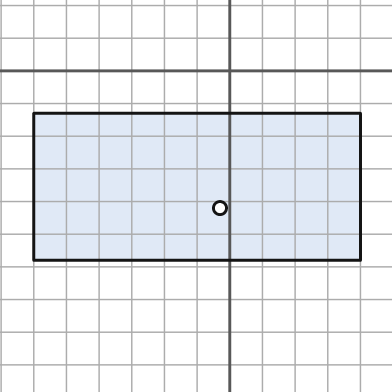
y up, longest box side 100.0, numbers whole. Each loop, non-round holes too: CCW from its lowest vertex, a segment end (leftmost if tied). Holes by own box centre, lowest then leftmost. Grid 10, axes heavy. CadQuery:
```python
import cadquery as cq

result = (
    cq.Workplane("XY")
    .moveTo(-60.0, -58.0)
    .lineTo(40.0, -58.0)
    .lineTo(40.0, -13.0)
    .lineTo(-60.0, -13.0)
    .close()
    .moveTo(-3.0, -42.0)
    .circle(2.0)
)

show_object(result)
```